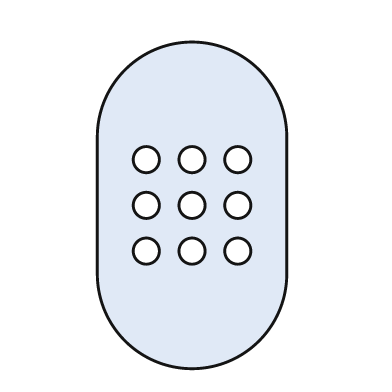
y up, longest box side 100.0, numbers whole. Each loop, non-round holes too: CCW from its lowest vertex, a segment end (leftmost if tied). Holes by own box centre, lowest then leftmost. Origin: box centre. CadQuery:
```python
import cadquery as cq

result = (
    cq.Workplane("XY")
    .moveTo(-29.0, -21.0)
    .threePointArc((0.0, -50.0), (29.0, -21.0))
    .lineTo(29.0, 21.0)
    .threePointArc((0.0, 50.0), (-29.0, 21.0))
    .close()
    .moveTo(-14.0, -14.0)
    .circle(4.0)
    .moveTo(0.0, -14.0)
    .circle(4.0)
    .moveTo(14.0, -14.0)
    .circle(4.0)
    .moveTo(-14.0, 0.0)
    .circle(4.0)
    .moveTo(0.0, 0.0)
    .circle(4.0)
    .moveTo(14.0, 0.0)
    .circle(4.0)
    .moveTo(-14.0, 14.0)
    .circle(4.0)
    .moveTo(0.0, 14.0)
    .circle(4.0)
    .moveTo(14.0, 14.0)
    .circle(4.0)
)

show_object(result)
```